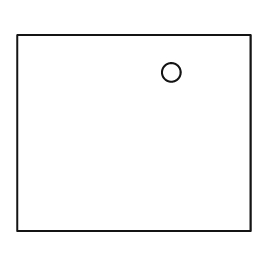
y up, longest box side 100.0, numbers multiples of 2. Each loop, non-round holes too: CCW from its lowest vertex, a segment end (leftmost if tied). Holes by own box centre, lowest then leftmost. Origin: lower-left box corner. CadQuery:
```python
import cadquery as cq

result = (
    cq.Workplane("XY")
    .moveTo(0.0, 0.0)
    .lineTo(100.0, 0.0)
    .lineTo(100.0, 84.0)
    .lineTo(0.0, 84.0)
    .close()
    .moveTo(66.0, 68.0)
    .circle(4.0)
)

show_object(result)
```